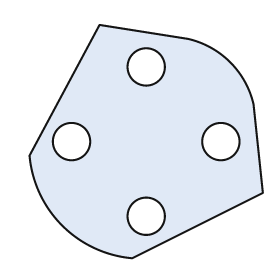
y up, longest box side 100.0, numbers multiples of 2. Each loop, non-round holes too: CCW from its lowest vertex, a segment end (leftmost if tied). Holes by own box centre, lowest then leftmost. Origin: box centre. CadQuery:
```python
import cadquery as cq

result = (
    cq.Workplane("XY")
    .moveTo(-6.0, -50.0)
    .lineTo(50.0, -22.0)
    .lineTo(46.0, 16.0)
    .threePointArc((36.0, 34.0), (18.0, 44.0))
    .lineTo(-20.0, 50.0)
    .lineTo(-50.0, -6.0)
    .threePointArc((-36.0, -36.0), (-6.0, -50.0))
    .close()
    .moveTo(0.0, -32.0)
    .circle(8.0)
    .moveTo(-32.0, 0.0)
    .circle(8.0)
    .moveTo(32.0, 0.0)
    .circle(8.0)
    .moveTo(0.0, 32.0)
    .circle(8.0)
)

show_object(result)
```